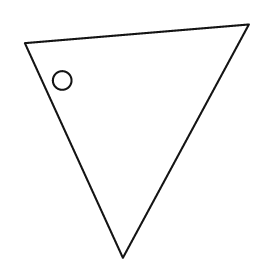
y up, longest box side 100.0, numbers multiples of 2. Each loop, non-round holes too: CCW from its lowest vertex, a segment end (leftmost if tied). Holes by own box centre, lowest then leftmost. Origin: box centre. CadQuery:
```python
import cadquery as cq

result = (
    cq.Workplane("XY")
    .moveTo(-6.0, -50.0)
    .lineTo(48.0, 50.0)
    .lineTo(-48.0, 42.0)
    .close()
    .moveTo(-32.0, 26.0)
    .circle(4.0)
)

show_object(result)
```